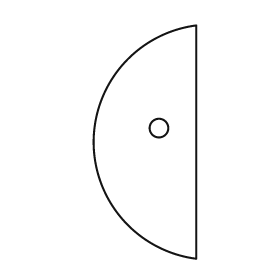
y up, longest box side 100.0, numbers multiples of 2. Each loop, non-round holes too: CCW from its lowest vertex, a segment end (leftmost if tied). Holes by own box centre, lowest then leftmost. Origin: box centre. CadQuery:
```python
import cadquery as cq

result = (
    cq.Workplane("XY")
    .moveTo(22.0, -50.0)
    .lineTo(22.0, 50.0)
    .threePointArc((-22.0, 0.0), (22.0, -50.0))
    .close()
    .moveTo(6.0, 6.0)
    .circle(4.0)
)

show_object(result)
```